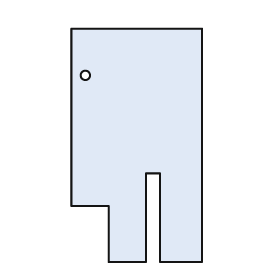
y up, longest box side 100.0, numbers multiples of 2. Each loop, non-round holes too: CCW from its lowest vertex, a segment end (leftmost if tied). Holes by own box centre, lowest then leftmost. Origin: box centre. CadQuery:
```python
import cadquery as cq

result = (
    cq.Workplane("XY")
    .moveTo(-12.0, -50.0)
    .lineTo(4.0, -50.0)
    .lineTo(4.0, -12.0)
    .lineTo(10.0, -12.0)
    .lineTo(10.0, -50.0)
    .lineTo(28.0, -50.0)
    .lineTo(28.0, 50.0)
    .lineTo(-28.0, 50.0)
    .lineTo(-28.0, -26.0)
    .lineTo(-12.0, -26.0)
    .close()
    .moveTo(-22.0, 30.0)
    .circle(2.0)
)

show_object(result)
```